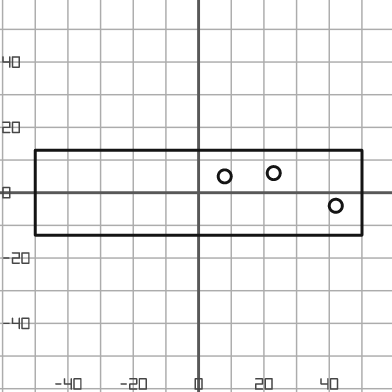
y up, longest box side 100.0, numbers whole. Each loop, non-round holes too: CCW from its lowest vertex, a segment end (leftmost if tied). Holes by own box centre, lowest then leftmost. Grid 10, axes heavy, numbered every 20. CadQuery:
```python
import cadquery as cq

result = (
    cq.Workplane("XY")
    .moveTo(-50.0, -13.0)
    .lineTo(50.0, -13.0)
    .lineTo(50.0, 13.0)
    .lineTo(-50.0, 13.0)
    .close()
    .moveTo(42.0, -4.0)
    .circle(2.0)
    .moveTo(8.0, 5.0)
    .circle(2.0)
    .moveTo(23.0, 6.0)
    .circle(2.0)
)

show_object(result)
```